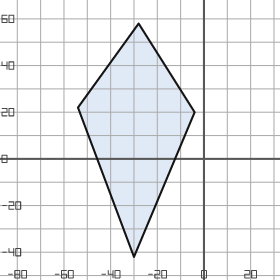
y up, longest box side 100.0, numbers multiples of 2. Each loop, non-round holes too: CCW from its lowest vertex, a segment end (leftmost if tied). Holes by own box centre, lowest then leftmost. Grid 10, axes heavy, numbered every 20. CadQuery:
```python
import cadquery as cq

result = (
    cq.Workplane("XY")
    .moveTo(-30.0, -42.0)
    .lineTo(-4.0, 20.0)
    .lineTo(-28.0, 58.0)
    .lineTo(-54.0, 22.0)
    .close()
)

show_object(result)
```